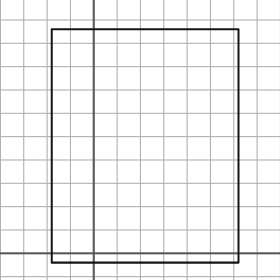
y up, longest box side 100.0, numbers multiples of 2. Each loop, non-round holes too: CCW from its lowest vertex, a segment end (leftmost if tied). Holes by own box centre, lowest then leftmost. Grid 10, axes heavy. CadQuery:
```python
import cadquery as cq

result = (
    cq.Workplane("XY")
    .moveTo(-18.0, -4.0)
    .lineTo(62.0, -4.0)
    .lineTo(62.0, 96.0)
    .lineTo(-18.0, 96.0)
    .close()
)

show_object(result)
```